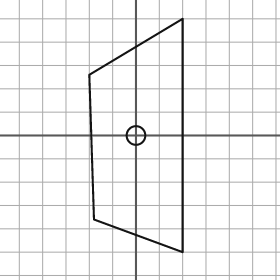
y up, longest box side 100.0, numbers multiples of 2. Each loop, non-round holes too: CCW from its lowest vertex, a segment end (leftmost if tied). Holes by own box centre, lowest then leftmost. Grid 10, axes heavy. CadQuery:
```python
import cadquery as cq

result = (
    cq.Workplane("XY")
    .moveTo(20.0, -50.0)
    .lineTo(20.0, 50.0)
    .lineTo(-20.0, 26.0)
    .lineTo(-18.0, -36.0)
    .close()
    .moveTo(0.0, 0.0)
    .circle(4.0)
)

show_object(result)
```